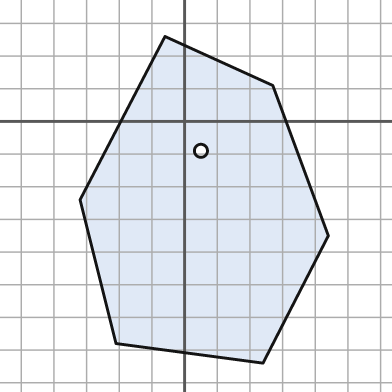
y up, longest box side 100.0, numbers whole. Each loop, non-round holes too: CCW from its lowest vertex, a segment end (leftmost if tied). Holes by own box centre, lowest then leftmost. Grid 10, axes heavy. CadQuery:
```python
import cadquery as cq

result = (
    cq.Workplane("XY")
    .moveTo(24.0, -74.0)
    .lineTo(44.0, -35.0)
    .lineTo(27.0, 11.0)
    .lineTo(-6.0, 26.0)
    .lineTo(-32.0, -24.0)
    .lineTo(-21.0, -68.0)
    .close()
    .moveTo(5.0, -9.0)
    .circle(2.0)
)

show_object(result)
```